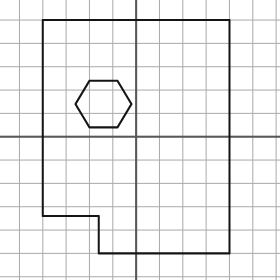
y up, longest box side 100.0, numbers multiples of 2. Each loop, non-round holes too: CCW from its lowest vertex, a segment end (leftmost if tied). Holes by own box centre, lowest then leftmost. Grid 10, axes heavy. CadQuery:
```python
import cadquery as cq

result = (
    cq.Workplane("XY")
    .moveTo(-16.0, -50.0)
    .lineTo(40.0, -50.0)
    .lineTo(40.0, 50.0)
    .lineTo(-40.0, 50.0)
    .lineTo(-40.0, -34.0)
    .lineTo(-16.0, -34.0)
    .close()
    .moveTo(-20.0, 4.0)
    .lineTo(-8.0, 4.0)
    .lineTo(-2.0, 14.0)
    .lineTo(-8.0, 24.0)
    .lineTo(-20.0, 24.0)
    .lineTo(-26.0, 14.0)
    .close()
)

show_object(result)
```